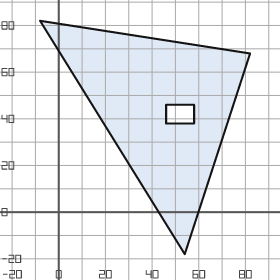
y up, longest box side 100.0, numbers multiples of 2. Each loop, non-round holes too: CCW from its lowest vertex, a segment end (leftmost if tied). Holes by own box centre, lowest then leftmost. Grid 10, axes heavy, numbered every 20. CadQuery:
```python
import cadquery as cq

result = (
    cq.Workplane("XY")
    .moveTo(54.0, -18.0)
    .lineTo(82.0, 68.0)
    .lineTo(-8.0, 82.0)
    .close()
    .moveTo(46.0, 38.0)
    .lineTo(58.0, 38.0)
    .lineTo(58.0, 46.0)
    .lineTo(46.0, 46.0)
    .close()
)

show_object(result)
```